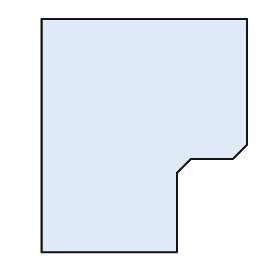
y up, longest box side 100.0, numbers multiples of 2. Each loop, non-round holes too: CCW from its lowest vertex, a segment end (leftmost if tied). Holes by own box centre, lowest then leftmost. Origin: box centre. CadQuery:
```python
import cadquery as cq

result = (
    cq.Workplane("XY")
    .moveTo(-44.0, -50.0)
    .lineTo(14.0, -50.0)
    .lineTo(14.0, -16.0)
    .lineTo(20.0, -10.0)
    .lineTo(38.0, -10.0)
    .lineTo(44.0, -4.0)
    .lineTo(44.0, 50.0)
    .lineTo(-44.0, 50.0)
    .close()
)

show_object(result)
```